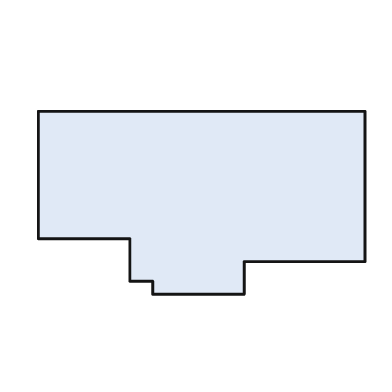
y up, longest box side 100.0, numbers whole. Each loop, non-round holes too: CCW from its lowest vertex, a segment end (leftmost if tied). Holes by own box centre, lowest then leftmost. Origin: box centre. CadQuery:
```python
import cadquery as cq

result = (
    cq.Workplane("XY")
    .moveTo(-15.0, -28.0)
    .lineTo(13.0, -28.0)
    .lineTo(13.0, -18.0)
    .lineTo(50.0, -18.0)
    .lineTo(50.0, 28.0)
    .lineTo(-50.0, 28.0)
    .lineTo(-50.0, -11.0)
    .lineTo(-22.0, -11.0)
    .lineTo(-22.0, -24.0)
    .lineTo(-15.0, -24.0)
    .close()
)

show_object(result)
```